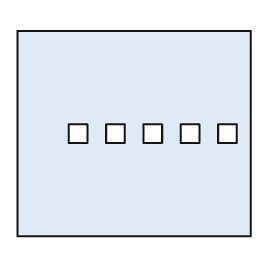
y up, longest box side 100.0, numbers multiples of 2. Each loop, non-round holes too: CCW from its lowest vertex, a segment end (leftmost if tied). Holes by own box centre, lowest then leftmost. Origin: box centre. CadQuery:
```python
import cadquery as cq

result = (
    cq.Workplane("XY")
    .moveTo(-50.0, -44.0)
    .lineTo(50.0, -44.0)
    .lineTo(50.0, 44.0)
    .lineTo(-50.0, 44.0)
    .close()
    .moveTo(-28.0, -4.0)
    .lineTo(-20.0, -4.0)
    .lineTo(-20.0, 4.0)
    .lineTo(-28.0, 4.0)
    .close()
    .moveTo(-12.0, -4.0)
    .lineTo(-4.0, -4.0)
    .lineTo(-4.0, 4.0)
    .lineTo(-12.0, 4.0)
    .close()
    .moveTo(4.0, -4.0)
    .lineTo(12.0, -4.0)
    .lineTo(12.0, 4.0)
    .lineTo(4.0, 4.0)
    .close()
    .moveTo(20.0, -4.0)
    .lineTo(28.0, -4.0)
    .lineTo(28.0, 4.0)
    .lineTo(20.0, 4.0)
    .close()
    .moveTo(36.0, -4.0)
    .lineTo(44.0, -4.0)
    .lineTo(44.0, 4.0)
    .lineTo(36.0, 4.0)
    .close()
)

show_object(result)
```